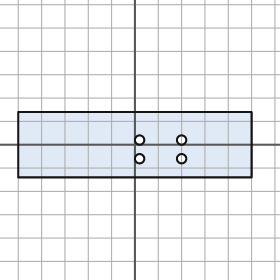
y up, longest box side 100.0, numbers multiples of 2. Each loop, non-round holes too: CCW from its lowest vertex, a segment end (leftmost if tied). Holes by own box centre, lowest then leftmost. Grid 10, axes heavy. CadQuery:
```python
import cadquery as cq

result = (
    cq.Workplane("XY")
    .moveTo(-50.0, -14.0)
    .lineTo(50.0, -14.0)
    .lineTo(50.0, 14.0)
    .lineTo(-50.0, 14.0)
    .close()
    .moveTo(2.0, -6.0)
    .circle(2.0)
    .moveTo(20.0, -6.0)
    .circle(2.0)
    .moveTo(2.0, 2.0)
    .circle(2.0)
    .moveTo(20.0, 2.0)
    .circle(2.0)
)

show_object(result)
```